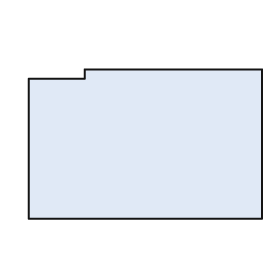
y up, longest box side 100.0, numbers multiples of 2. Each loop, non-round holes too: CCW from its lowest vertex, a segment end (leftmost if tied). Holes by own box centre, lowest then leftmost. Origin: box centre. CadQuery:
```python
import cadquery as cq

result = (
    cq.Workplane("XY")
    .moveTo(-50.0, -32.0)
    .lineTo(50.0, -32.0)
    .lineTo(50.0, 32.0)
    .lineTo(-26.0, 32.0)
    .lineTo(-26.0, 28.0)
    .lineTo(-50.0, 28.0)
    .close()
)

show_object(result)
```